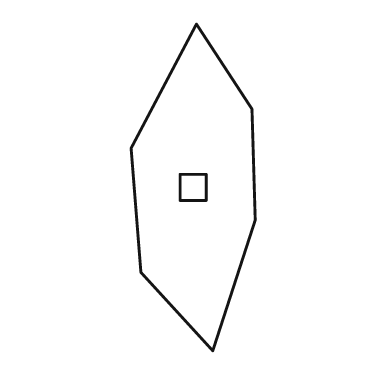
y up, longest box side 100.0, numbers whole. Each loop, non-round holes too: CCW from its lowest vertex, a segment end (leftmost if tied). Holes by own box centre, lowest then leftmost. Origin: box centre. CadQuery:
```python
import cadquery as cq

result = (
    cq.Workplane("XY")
    .moveTo(6.0, -50.0)
    .lineTo(19.0, -10.0)
    .lineTo(18.0, 24.0)
    .lineTo(1.0, 50.0)
    .lineTo(-19.0, 12.0)
    .lineTo(-16.0, -26.0)
    .close()
    .moveTo(-4.0, -4.0)
    .lineTo(4.0, -4.0)
    .lineTo(4.0, 4.0)
    .lineTo(-4.0, 4.0)
    .close()
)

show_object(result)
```